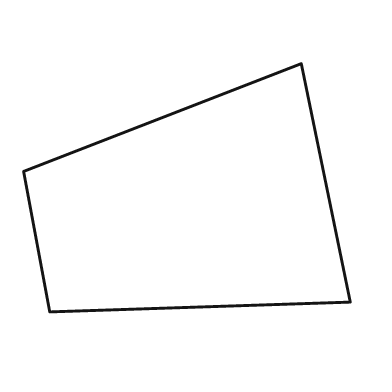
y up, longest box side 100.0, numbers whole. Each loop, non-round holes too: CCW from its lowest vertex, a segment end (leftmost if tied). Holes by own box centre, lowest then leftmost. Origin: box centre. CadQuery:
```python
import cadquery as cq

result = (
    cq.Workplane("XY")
    .moveTo(-42.0, -38.0)
    .lineTo(50.0, -35.0)
    .lineTo(35.0, 38.0)
    .lineTo(-50.0, 5.0)
    .close()
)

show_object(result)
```